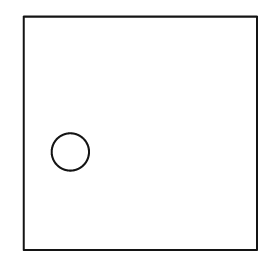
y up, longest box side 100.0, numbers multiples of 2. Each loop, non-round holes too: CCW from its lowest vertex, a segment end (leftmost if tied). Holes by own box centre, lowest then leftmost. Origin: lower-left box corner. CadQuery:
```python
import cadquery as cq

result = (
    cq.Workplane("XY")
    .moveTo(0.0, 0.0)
    .lineTo(100.0, 0.0)
    .lineTo(100.0, 100.0)
    .lineTo(0.0, 100.0)
    .close()
    .moveTo(20.0, 42.0)
    .circle(8.0)
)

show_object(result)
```